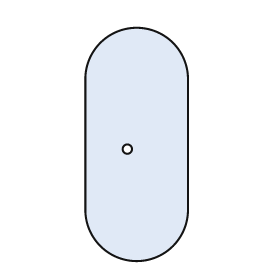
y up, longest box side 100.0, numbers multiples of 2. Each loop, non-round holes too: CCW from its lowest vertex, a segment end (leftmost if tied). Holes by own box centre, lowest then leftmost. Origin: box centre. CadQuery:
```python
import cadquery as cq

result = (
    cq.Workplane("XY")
    .moveTo(-22.0, -28.0)
    .threePointArc((0.0, -50.0), (22.0, -28.0))
    .lineTo(22.0, 28.0)
    .threePointArc((0.0, 50.0), (-22.0, 28.0))
    .close()
    .moveTo(-4.0, -2.0)
    .circle(2.0)
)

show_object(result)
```